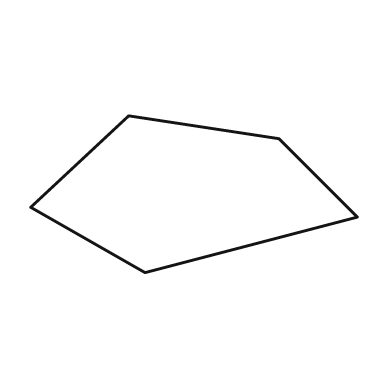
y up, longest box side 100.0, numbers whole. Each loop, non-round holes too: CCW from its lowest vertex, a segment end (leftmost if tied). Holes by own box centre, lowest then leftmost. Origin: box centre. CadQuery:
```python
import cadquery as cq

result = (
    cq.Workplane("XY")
    .moveTo(-15.0, -24.0)
    .lineTo(50.0, -7.0)
    .lineTo(26.0, 17.0)
    .lineTo(-20.0, 24.0)
    .lineTo(-50.0, -4.0)
    .close()
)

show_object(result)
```